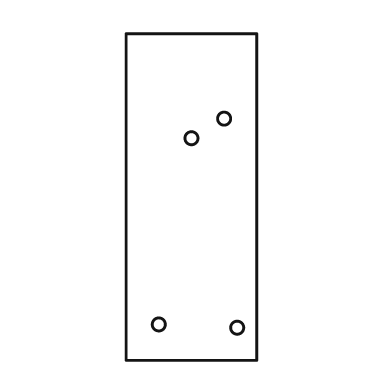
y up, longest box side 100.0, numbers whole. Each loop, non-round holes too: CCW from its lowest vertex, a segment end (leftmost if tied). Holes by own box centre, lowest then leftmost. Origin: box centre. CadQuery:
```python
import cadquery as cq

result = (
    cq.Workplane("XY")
    .moveTo(-20.0, -50.0)
    .lineTo(20.0, -50.0)
    .lineTo(20.0, 50.0)
    .lineTo(-20.0, 50.0)
    .close()
    .moveTo(14.0, -40.0)
    .circle(2.0)
    .moveTo(-10.0, -39.0)
    .circle(2.0)
    .moveTo(0.0, 18.0)
    .circle(2.0)
    .moveTo(10.0, 24.0)
    .circle(2.0)
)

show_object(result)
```